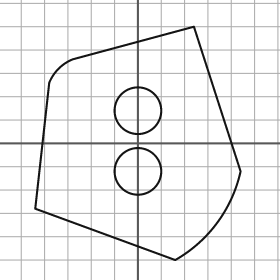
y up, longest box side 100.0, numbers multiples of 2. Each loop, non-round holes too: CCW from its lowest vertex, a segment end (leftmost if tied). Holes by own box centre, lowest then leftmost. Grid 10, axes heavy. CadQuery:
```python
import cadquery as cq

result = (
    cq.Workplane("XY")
    .moveTo(16.0, -50.0)
    .threePointArc((34.0, -34.0), (44.0, -12.0))
    .lineTo(24.0, 50.0)
    .lineTo(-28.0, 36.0)
    .threePointArc((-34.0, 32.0), (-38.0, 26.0))
    .lineTo(-44.0, -28.0)
    .close()
    .moveTo(0.0, -12.0)
    .circle(10.0)
    .moveTo(0.0, 14.0)
    .circle(10.0)
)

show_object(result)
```